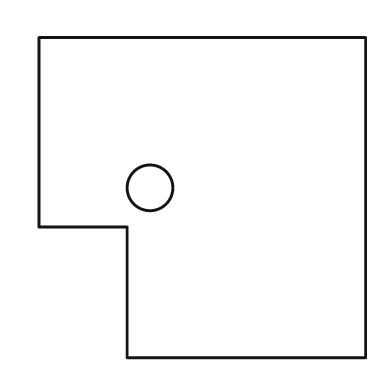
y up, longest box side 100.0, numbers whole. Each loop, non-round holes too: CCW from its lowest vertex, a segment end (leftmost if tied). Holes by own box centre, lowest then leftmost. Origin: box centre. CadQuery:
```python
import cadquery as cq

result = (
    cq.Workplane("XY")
    .moveTo(-23.0, -49.0)
    .lineTo(50.0, -49.0)
    .lineTo(50.0, 49.0)
    .lineTo(-50.0, 49.0)
    .lineTo(-50.0, -9.0)
    .lineTo(-23.0, -9.0)
    .close()
    .moveTo(-16.0, 3.0)
    .circle(7.0)
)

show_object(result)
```